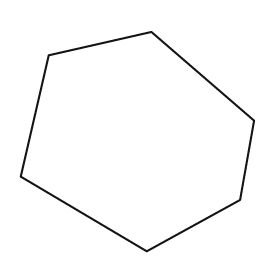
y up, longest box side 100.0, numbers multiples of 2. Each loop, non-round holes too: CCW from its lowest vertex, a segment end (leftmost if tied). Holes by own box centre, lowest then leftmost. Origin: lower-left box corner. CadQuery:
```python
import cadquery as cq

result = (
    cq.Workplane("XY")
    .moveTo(54.0, 0.0)
    .lineTo(94.0, 22.0)
    .lineTo(100.0, 56.0)
    .lineTo(56.0, 94.0)
    .lineTo(12.0, 84.0)
    .lineTo(0.0, 32.0)
    .close()
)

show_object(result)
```